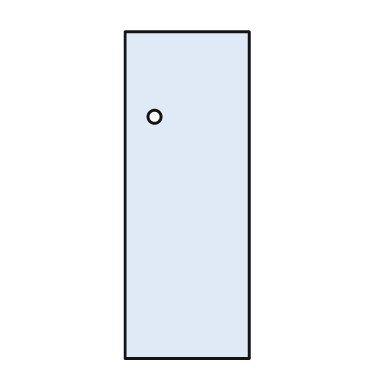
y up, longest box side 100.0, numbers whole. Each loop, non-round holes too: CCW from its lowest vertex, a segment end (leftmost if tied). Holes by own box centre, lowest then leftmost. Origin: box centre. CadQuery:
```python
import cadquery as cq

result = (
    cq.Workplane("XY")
    .moveTo(-19.0, -50.0)
    .lineTo(19.0, -50.0)
    .lineTo(19.0, 50.0)
    .lineTo(-19.0, 50.0)
    .close()
    .moveTo(-10.0, 24.0)
    .circle(2.0)
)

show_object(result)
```